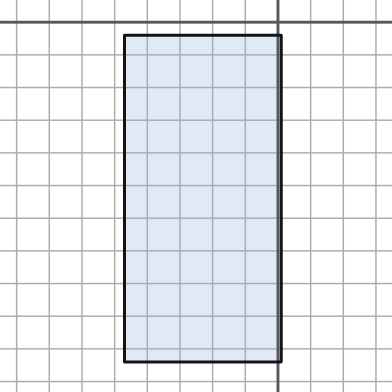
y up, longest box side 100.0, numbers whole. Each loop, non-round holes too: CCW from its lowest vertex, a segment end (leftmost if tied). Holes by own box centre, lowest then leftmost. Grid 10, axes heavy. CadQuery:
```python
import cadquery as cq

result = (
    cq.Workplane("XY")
    .moveTo(-47.0, -104.0)
    .lineTo(1.0, -104.0)
    .lineTo(1.0, -4.0)
    .lineTo(-47.0, -4.0)
    .close()
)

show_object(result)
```